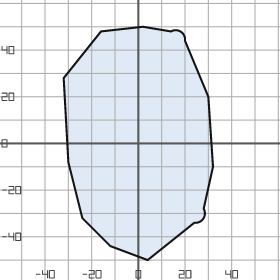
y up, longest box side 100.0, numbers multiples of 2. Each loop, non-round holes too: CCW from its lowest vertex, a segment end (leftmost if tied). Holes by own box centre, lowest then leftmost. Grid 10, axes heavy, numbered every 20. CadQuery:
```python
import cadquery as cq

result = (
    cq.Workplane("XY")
    .moveTo(4.0, -50.0)
    .lineTo(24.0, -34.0)
    .threePointArc((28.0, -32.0), (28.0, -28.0))
    .lineTo(32.0, -10.0)
    .lineTo(30.0, 20.0)
    .lineTo(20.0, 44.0)
    .threePointArc((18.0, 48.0), (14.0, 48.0))
    .lineTo(2.0, 50.0)
    .lineTo(-16.0, 48.0)
    .lineTo(-32.0, 28.0)
    .lineTo(-30.0, -8.0)
    .lineTo(-24.0, -32.0)
    .lineTo(-12.0, -44.0)
    .close()
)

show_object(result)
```